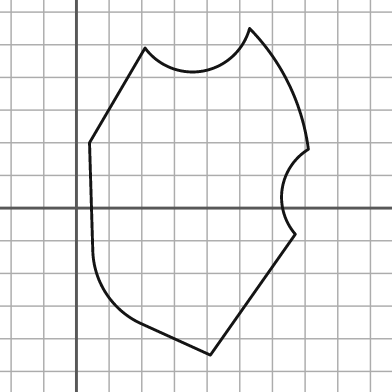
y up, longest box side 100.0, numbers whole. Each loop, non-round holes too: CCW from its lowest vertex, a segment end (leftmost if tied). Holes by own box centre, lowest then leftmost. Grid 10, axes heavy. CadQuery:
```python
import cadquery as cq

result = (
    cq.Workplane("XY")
    .moveTo(41.0, -45.0)
    .lineTo(67.0, -8.0)
    .threePointArc((63.0, 6.0), (71.0, 18.0))
    .threePointArc((65.0, 38.0), (53.0, 55.0))
    .threePointArc((39.0, 42.0), (21.0, 49.0))
    .lineTo(4.0, 20.0)
    .lineTo(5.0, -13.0)
    .threePointArc((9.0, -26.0), (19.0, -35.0))
    .close()
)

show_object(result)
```